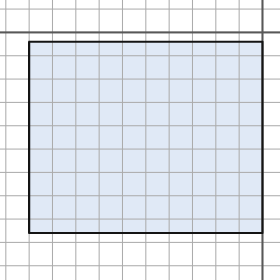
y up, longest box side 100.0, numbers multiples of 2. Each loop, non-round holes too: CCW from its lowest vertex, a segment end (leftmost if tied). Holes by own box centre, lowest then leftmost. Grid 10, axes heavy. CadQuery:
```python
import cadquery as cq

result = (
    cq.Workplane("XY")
    .moveTo(-100.0, -86.0)
    .lineTo(0.0, -86.0)
    .lineTo(0.0, -4.0)
    .lineTo(-100.0, -4.0)
    .close()
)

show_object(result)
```